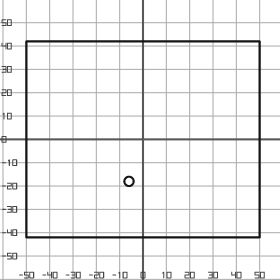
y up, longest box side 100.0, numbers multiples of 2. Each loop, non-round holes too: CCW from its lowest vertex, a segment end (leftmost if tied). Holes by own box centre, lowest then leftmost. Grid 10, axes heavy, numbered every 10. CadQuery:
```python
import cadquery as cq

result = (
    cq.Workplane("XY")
    .moveTo(-50.0, -42.0)
    .lineTo(50.0, -42.0)
    .lineTo(50.0, 42.0)
    .lineTo(-50.0, 42.0)
    .close()
    .moveTo(-6.0, -18.0)
    .circle(2.0)
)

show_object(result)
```